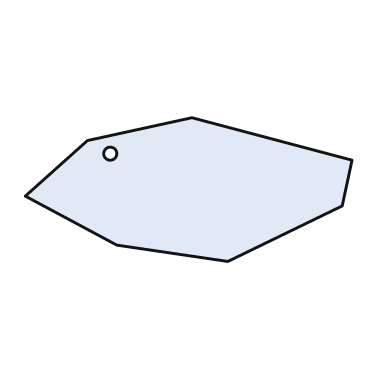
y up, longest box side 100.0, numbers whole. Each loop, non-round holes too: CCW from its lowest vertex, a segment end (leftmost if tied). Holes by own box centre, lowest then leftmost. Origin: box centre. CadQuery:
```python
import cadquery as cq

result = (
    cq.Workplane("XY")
    .moveTo(12.0, -22.0)
    .lineTo(47.0, -5.0)
    .lineTo(50.0, 9.0)
    .lineTo(1.0, 22.0)
    .lineTo(-31.0, 15.0)
    .lineTo(-50.0, -2.0)
    .lineTo(-22.0, -17.0)
    .close()
    .moveTo(-24.0, 11.0)
    .circle(2.0)
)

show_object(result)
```